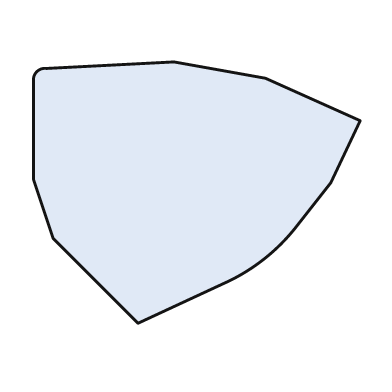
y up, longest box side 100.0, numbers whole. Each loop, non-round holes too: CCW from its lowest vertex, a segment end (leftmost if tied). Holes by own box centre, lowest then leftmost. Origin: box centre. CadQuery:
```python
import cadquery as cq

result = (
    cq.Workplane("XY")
    .moveTo(-18.0, -40.0)
    .lineTo(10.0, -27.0)
    .threePointArc((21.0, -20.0), (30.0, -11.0))
    .lineTo(41.0, 3.0)
    .lineTo(50.0, 22.0)
    .lineTo(21.0, 35.0)
    .lineTo(-7.0, 40.0)
    .lineTo(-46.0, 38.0)
    .threePointArc((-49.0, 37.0), (-50.0, 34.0))
    .lineTo(-50.0, 4.0)
    .lineTo(-44.0, -14.0)
    .close()
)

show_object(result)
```